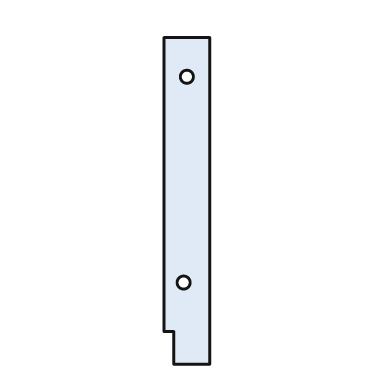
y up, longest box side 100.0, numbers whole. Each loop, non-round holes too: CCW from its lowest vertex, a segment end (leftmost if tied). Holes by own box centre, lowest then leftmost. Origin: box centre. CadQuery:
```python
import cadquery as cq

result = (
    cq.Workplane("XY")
    .moveTo(-4.0, -50.0)
    .lineTo(7.0, -50.0)
    .lineTo(7.0, 50.0)
    .lineTo(-7.0, 50.0)
    .lineTo(-7.0, -40.0)
    .lineTo(-4.0, -40.0)
    .close()
    .moveTo(-1.0, -25.0)
    .circle(2.0)
    .moveTo(0.0, 38.0)
    .circle(2.0)
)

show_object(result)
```